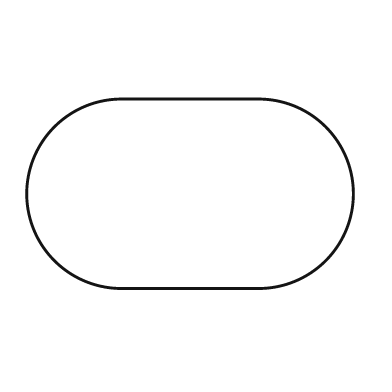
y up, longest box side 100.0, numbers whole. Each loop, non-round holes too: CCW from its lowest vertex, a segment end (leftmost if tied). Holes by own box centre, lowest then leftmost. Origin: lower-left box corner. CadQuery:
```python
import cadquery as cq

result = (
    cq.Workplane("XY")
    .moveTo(29.0, 0.0)
    .lineTo(71.0, 0.0)
    .threePointArc((100.0, 29.0), (71.0, 58.0))
    .lineTo(29.0, 58.0)
    .threePointArc((0.0, 29.0), (29.0, 0.0))
    .close()
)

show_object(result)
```